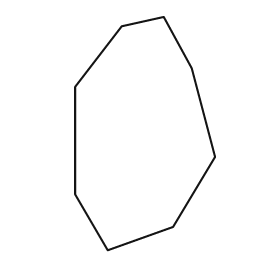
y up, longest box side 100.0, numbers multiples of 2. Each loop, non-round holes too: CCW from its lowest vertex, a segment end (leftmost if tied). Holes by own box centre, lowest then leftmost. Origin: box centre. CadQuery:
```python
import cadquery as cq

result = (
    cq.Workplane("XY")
    .moveTo(-16.0, -50.0)
    .lineTo(12.0, -40.0)
    .lineTo(30.0, -10.0)
    .lineTo(20.0, 28.0)
    .lineTo(8.0, 50.0)
    .lineTo(-10.0, 46.0)
    .lineTo(-30.0, 20.0)
    .lineTo(-30.0, -26.0)
    .close()
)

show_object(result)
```